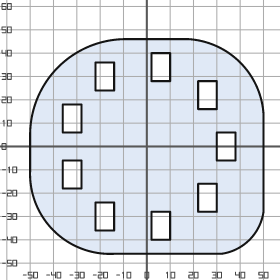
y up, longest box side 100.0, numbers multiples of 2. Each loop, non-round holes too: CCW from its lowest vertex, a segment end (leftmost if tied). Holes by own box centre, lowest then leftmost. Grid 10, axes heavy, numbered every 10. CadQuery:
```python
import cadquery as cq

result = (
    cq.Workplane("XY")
    .moveTo(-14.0, -46.0)
    .lineTo(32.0, -46.0)
    .threePointArc((44.0, -40.0), (50.0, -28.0))
    .lineTo(50.0, 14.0)
    .threePointArc((40.0, 36.0), (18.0, 46.0))
    .lineTo(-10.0, 46.0)
    .threePointArc((-38.0, 34.0), (-50.0, 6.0))
    .lineTo(-50.0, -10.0)
    .threePointArc((-40.0, -36.0), (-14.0, -46.0))
    .close()
    .moveTo(2.0, -40.0)
    .lineTo(10.0, -40.0)
    .lineTo(10.0, -28.0)
    .lineTo(2.0, -28.0)
    .close()
    .moveTo(-22.0, -36.0)
    .lineTo(-14.0, -36.0)
    .lineTo(-14.0, -24.0)
    .lineTo(-22.0, -24.0)
    .close()
    .moveTo(22.0, -28.0)
    .lineTo(30.0, -28.0)
    .lineTo(30.0, -16.0)
    .lineTo(22.0, -16.0)
    .close()
    .moveTo(-36.0, -18.0)
    .lineTo(-28.0, -18.0)
    .lineTo(-28.0, -6.0)
    .lineTo(-36.0, -6.0)
    .close()
    .moveTo(30.0, -6.0)
    .lineTo(38.0, -6.0)
    .lineTo(38.0, 6.0)
    .lineTo(30.0, 6.0)
    .close()
    .moveTo(-36.0, 6.0)
    .lineTo(-28.0, 6.0)
    .lineTo(-28.0, 18.0)
    .lineTo(-36.0, 18.0)
    .close()
    .moveTo(22.0, 16.0)
    .lineTo(30.0, 16.0)
    .lineTo(30.0, 28.0)
    .lineTo(22.0, 28.0)
    .close()
    .moveTo(-22.0, 24.0)
    .lineTo(-14.0, 24.0)
    .lineTo(-14.0, 36.0)
    .lineTo(-22.0, 36.0)
    .close()
    .moveTo(2.0, 28.0)
    .lineTo(10.0, 28.0)
    .lineTo(10.0, 40.0)
    .lineTo(2.0, 40.0)
    .close()
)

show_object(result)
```